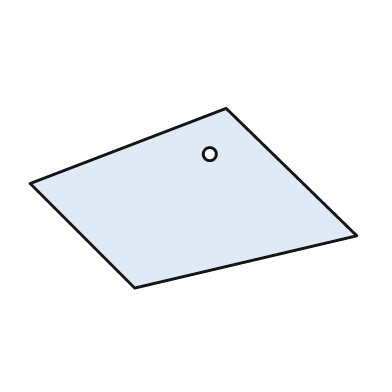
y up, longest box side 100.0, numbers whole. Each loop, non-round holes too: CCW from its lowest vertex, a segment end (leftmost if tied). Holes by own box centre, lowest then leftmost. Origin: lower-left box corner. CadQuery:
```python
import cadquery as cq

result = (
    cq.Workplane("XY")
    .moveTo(32.0, 0.0)
    .lineTo(100.0, 16.0)
    .lineTo(60.0, 55.0)
    .lineTo(0.0, 32.0)
    .close()
    .moveTo(55.0, 41.0)
    .circle(2.0)
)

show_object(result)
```